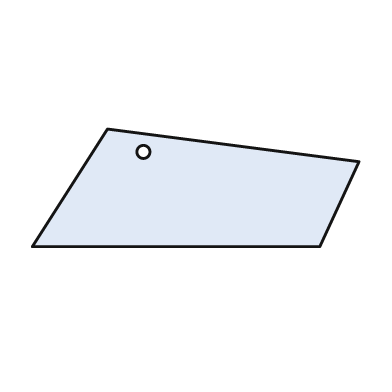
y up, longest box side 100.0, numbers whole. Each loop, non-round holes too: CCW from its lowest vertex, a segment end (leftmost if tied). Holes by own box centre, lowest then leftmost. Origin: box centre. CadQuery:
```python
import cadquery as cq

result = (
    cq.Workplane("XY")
    .moveTo(-50.0, -18.0)
    .lineTo(38.0, -18.0)
    .lineTo(50.0, 8.0)
    .lineTo(-27.0, 18.0)
    .close()
    .moveTo(-16.0, 11.0)
    .circle(2.0)
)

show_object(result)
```